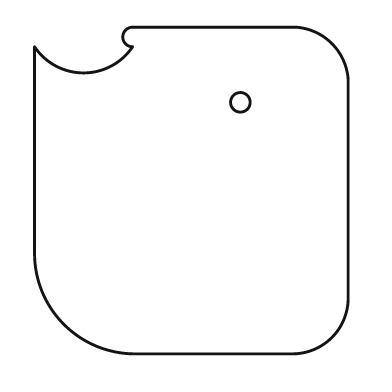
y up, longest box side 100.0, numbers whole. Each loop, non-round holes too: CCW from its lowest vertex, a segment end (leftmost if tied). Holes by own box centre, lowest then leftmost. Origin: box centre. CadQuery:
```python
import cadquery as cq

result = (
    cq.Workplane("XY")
    .moveTo(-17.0, -50.0)
    .lineTo(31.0, -50.0)
    .threePointArc((43.0, -45.0), (48.0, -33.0))
    .lineTo(48.0, 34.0)
    .threePointArc((43.0, 45.0), (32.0, 50.0))
    .lineTo(-18.0, 50.0)
    .threePointArc((-21.0, 47.0), (-18.0, 44.0))
    .threePointArc((-33.0, 36.0), (-48.0, 44.0))
    .lineTo(-48.0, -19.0)
    .threePointArc((-39.0, -41.0), (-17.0, -50.0))
    .close()
    .moveTo(15.0, 27.0)
    .circle(3.0)
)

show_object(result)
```